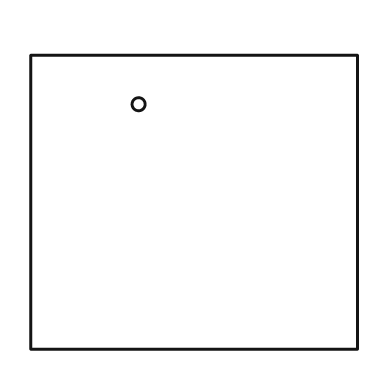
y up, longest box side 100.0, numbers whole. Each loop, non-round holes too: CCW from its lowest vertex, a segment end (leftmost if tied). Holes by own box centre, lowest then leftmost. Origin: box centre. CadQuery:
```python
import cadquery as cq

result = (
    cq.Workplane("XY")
    .moveTo(-50.0, -45.0)
    .lineTo(50.0, -45.0)
    .lineTo(50.0, 45.0)
    .lineTo(-50.0, 45.0)
    .close()
    .moveTo(-17.0, 30.0)
    .circle(2.0)
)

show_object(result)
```